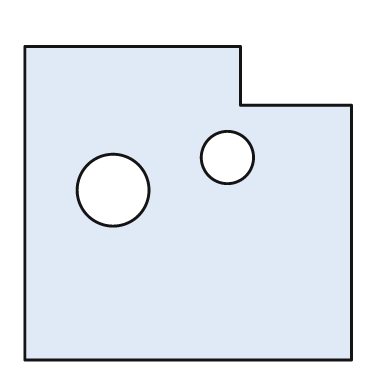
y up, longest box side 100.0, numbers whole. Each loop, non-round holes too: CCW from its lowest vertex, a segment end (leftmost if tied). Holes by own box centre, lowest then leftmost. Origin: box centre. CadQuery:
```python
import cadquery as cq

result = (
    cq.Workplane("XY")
    .moveTo(-50.0, -48.0)
    .lineTo(50.0, -48.0)
    .lineTo(50.0, 30.0)
    .lineTo(16.0, 30.0)
    .lineTo(16.0, 48.0)
    .lineTo(-50.0, 48.0)
    .close()
    .moveTo(-23.0, 4.0)
    .circle(11.0)
    .moveTo(12.0, 14.0)
    .circle(8.0)
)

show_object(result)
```